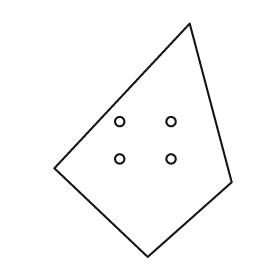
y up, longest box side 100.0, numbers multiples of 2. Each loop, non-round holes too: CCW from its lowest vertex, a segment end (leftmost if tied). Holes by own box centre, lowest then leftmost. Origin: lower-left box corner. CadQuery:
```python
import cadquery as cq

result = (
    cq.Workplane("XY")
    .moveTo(40.0, 0.0)
    .lineTo(76.0, 32.0)
    .lineTo(58.0, 100.0)
    .lineTo(0.0, 38.0)
    .close()
    .moveTo(28.0, 42.0)
    .circle(2.0)
    .moveTo(50.0, 42.0)
    .circle(2.0)
    .moveTo(28.0, 58.0)
    .circle(2.0)
    .moveTo(50.0, 58.0)
    .circle(2.0)
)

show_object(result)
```